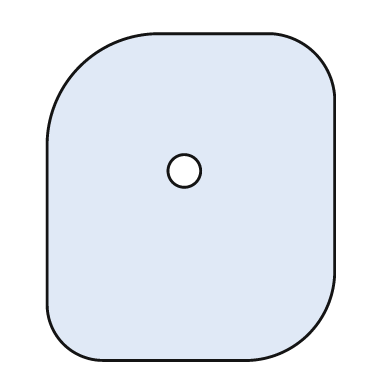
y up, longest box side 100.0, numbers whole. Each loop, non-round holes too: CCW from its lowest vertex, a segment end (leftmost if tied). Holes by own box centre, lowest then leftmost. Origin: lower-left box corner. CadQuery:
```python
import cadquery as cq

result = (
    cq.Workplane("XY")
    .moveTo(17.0, 0.0)
    .lineTo(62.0, 0.0)
    .threePointArc((80.0, 8.0), (88.0, 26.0))
    .lineTo(88.0, 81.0)
    .threePointArc((82.0, 94.0), (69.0, 100.0))
    .lineTo(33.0, 100.0)
    .threePointArc((10.0, 90.0), (0.0, 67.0))
    .lineTo(0.0, 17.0)
    .threePointArc((5.0, 5.0), (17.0, 0.0))
    .close()
    .moveTo(42.0, 58.0)
    .circle(5.0)
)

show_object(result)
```